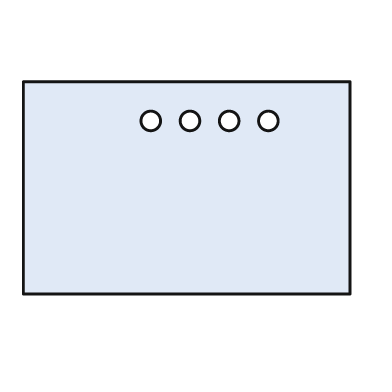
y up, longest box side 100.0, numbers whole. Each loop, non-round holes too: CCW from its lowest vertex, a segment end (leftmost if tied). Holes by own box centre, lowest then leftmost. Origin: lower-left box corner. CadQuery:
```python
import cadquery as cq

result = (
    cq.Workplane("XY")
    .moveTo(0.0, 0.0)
    .lineTo(100.0, 0.0)
    .lineTo(100.0, 65.0)
    .lineTo(0.0, 65.0)
    .close()
    .moveTo(39.0, 53.0)
    .circle(3.0)
    .moveTo(51.0, 53.0)
    .circle(3.0)
    .moveTo(63.0, 53.0)
    .circle(3.0)
    .moveTo(75.0, 53.0)
    .circle(3.0)
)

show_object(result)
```